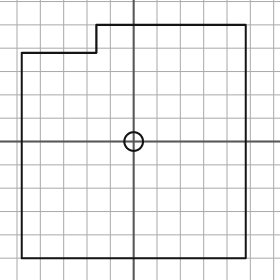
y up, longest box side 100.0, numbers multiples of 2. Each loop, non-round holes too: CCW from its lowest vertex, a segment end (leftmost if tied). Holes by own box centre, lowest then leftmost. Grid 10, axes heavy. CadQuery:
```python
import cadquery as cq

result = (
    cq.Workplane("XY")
    .moveTo(-48.0, -50.0)
    .lineTo(48.0, -50.0)
    .lineTo(48.0, 50.0)
    .lineTo(-16.0, 50.0)
    .lineTo(-16.0, 38.0)
    .lineTo(-48.0, 38.0)
    .close()
    .moveTo(0.0, 0.0)
    .circle(4.0)
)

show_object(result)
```